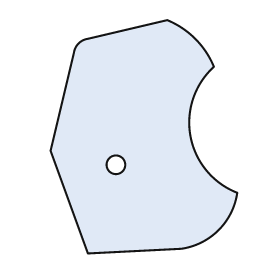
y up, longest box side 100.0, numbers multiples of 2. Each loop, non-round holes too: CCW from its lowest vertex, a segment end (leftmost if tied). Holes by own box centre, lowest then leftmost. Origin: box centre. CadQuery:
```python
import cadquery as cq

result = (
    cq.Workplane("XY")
    .moveTo(-24.0, -50.0)
    .lineTo(16.0, -48.0)
    .threePointArc((32.0, -40.0), (40.0, -24.0))
    .threePointArc((20.0, 0.0), (30.0, 30.0))
    .threePointArc((22.0, 42.0), (10.0, 50.0))
    .lineTo(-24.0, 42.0)
    .threePointArc((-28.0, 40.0), (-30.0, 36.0))
    .lineTo(-40.0, -6.0)
    .close()
    .moveTo(-12.0, -12.0)
    .circle(4.0)
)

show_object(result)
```